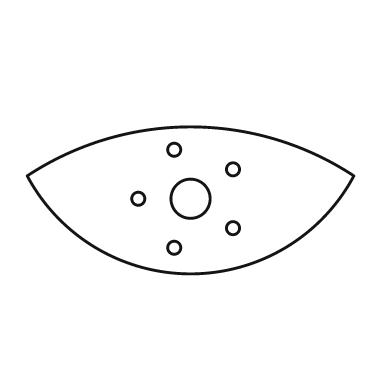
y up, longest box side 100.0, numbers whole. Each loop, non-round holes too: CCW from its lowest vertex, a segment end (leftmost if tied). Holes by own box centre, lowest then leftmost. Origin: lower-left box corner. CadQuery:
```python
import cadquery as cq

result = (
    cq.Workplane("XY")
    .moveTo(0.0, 30.0)
    .threePointArc((50.0, 0.0), (100.0, 30.0))
    .threePointArc((50.0, 45.0), (0.0, 30.0))
    .close()
    .moveTo(45.0, 8.0)
    .circle(2.0)
    .moveTo(63.0, 14.0)
    .circle(2.0)
    .moveTo(34.0, 23.0)
    .circle(2.0)
    .moveTo(50.0, 23.0)
    .circle(6.0)
    .moveTo(63.0, 32.0)
    .circle(2.0)
    .moveTo(45.0, 38.0)
    .circle(2.0)
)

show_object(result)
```